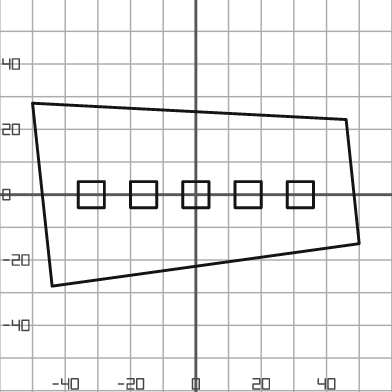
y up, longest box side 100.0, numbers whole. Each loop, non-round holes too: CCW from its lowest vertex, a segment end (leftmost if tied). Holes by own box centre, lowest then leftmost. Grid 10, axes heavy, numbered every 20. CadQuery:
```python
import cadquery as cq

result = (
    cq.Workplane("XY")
    .moveTo(-44.0, -28.0)
    .lineTo(50.0, -15.0)
    .lineTo(46.0, 23.0)
    .lineTo(-50.0, 28.0)
    .close()
    .moveTo(-36.0, -4.0)
    .lineTo(-28.0, -4.0)
    .lineTo(-28.0, 4.0)
    .lineTo(-36.0, 4.0)
    .close()
    .moveTo(-20.0, -4.0)
    .lineTo(-12.0, -4.0)
    .lineTo(-12.0, 4.0)
    .lineTo(-20.0, 4.0)
    .close()
    .moveTo(-4.0, -4.0)
    .lineTo(4.0, -4.0)
    .lineTo(4.0, 4.0)
    .lineTo(-4.0, 4.0)
    .close()
    .moveTo(12.0, -4.0)
    .lineTo(20.0, -4.0)
    .lineTo(20.0, 4.0)
    .lineTo(12.0, 4.0)
    .close()
    .moveTo(28.0, -4.0)
    .lineTo(36.0, -4.0)
    .lineTo(36.0, 4.0)
    .lineTo(28.0, 4.0)
    .close()
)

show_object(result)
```